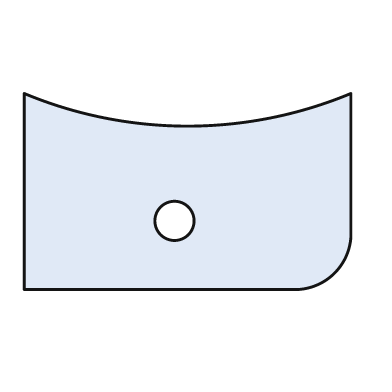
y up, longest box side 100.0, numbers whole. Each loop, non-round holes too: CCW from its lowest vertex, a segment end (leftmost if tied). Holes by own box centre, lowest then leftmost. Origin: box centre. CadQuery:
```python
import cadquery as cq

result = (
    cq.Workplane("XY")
    .moveTo(-50.0, -30.0)
    .lineTo(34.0, -30.0)
    .threePointArc((45.0, -25.0), (50.0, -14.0))
    .lineTo(50.0, 30.0)
    .threePointArc((0.0, 20.0), (-50.0, 30.0))
    .close()
    .moveTo(-4.0, -9.0)
    .circle(6.0)
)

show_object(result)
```